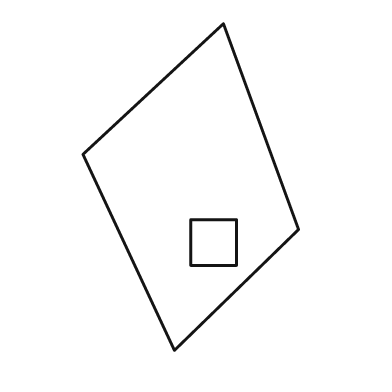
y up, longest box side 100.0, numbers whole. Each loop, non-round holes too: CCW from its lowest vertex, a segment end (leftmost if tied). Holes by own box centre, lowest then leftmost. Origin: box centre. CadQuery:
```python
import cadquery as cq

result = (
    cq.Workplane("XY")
    .moveTo(-5.0, -50.0)
    .lineTo(33.0, -13.0)
    .lineTo(10.0, 50.0)
    .lineTo(-33.0, 10.0)
    .close()
    .moveTo(0.0, -24.0)
    .lineTo(14.0, -24.0)
    .lineTo(14.0, -10.0)
    .lineTo(0.0, -10.0)
    .close()
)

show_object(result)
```